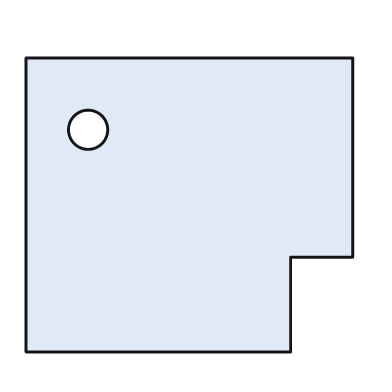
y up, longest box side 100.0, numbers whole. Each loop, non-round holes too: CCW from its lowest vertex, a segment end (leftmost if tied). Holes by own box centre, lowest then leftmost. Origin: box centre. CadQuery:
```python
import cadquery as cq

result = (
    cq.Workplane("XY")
    .moveTo(-50.0, -45.0)
    .lineTo(31.0, -45.0)
    .lineTo(31.0, -16.0)
    .lineTo(50.0, -16.0)
    .lineTo(50.0, 45.0)
    .lineTo(-50.0, 45.0)
    .close()
    .moveTo(-31.0, 23.0)
    .circle(6.0)
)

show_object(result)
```